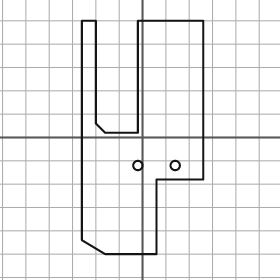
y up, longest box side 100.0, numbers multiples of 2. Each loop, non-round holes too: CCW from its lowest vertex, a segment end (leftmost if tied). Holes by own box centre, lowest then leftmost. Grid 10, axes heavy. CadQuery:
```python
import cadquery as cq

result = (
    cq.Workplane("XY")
    .moveTo(-16.0, -50.0)
    .lineTo(6.0, -50.0)
    .lineTo(6.0, -18.0)
    .lineTo(26.0, -18.0)
    .lineTo(26.0, 50.0)
    .lineTo(-2.0, 50.0)
    .lineTo(-2.0, 2.0)
    .lineTo(-16.0, 2.0)
    .lineTo(-20.0, 6.0)
    .lineTo(-20.0, 50.0)
    .lineTo(-26.0, 50.0)
    .lineTo(-26.0, -44.0)
    .close()
    .moveTo(-2.0, -12.0)
    .circle(2.0)
    .moveTo(14.0, -12.0)
    .circle(2.0)
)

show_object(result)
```